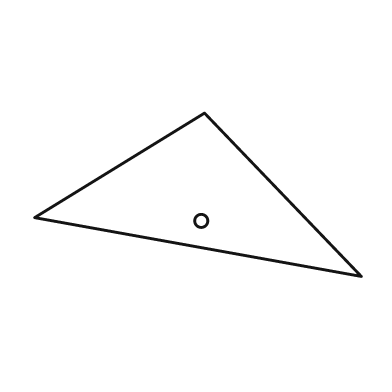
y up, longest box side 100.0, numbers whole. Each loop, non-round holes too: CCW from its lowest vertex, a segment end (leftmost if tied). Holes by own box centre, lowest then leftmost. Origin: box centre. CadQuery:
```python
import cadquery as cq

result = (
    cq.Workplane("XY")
    .moveTo(50.0, -25.0)
    .lineTo(2.0, 25.0)
    .lineTo(-50.0, -7.0)
    .close()
    .moveTo(1.0, -8.0)
    .circle(2.0)
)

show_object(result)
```